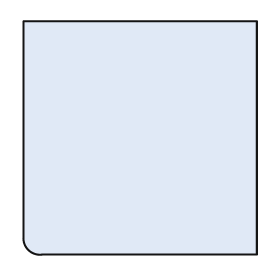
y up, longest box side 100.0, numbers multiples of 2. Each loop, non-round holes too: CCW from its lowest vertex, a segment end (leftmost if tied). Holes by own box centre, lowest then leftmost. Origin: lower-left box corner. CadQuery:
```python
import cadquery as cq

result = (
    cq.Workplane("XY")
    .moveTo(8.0, 0.0)
    .lineTo(100.0, 0.0)
    .lineTo(100.0, 100.0)
    .lineTo(0.0, 100.0)
    .lineTo(0.0, 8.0)
    .threePointArc((2.0, 2.0), (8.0, 0.0))
    .close()
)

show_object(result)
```